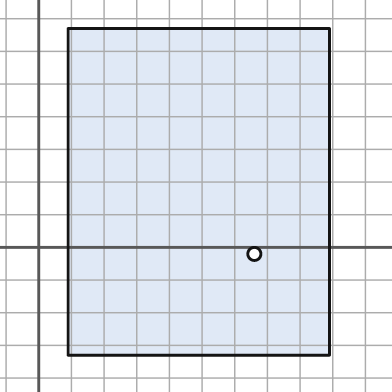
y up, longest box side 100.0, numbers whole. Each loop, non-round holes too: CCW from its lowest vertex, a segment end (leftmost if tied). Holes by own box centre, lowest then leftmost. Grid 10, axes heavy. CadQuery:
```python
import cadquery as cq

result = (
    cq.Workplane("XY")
    .moveTo(9.0, -33.0)
    .lineTo(89.0, -33.0)
    .lineTo(89.0, 67.0)
    .lineTo(9.0, 67.0)
    .close()
    .moveTo(66.0, -2.0)
    .circle(2.0)
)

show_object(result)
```